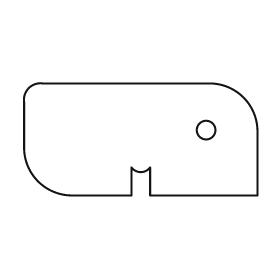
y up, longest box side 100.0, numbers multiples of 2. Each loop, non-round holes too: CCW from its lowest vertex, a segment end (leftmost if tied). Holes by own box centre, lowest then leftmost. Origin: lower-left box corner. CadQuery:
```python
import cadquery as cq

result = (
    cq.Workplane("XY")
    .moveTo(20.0, 0.0)
    .lineTo(46.0, 0.0)
    .lineTo(46.0, 12.0)
    .threePointArc((50.0, 10.0), (54.0, 12.0))
    .lineTo(54.0, 0.0)
    .lineTo(100.0, 0.0)
    .lineTo(100.0, 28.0)
    .threePointArc((94.0, 42.0), (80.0, 48.0))
    .lineTo(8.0, 48.0)
    .threePointArc((2.0, 46.0), (0.0, 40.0))
    .lineTo(0.0, 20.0)
    .threePointArc((6.0, 6.0), (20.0, 0.0))
    .close()
    .moveTo(78.0, 28.0)
    .circle(4.0)
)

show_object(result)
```